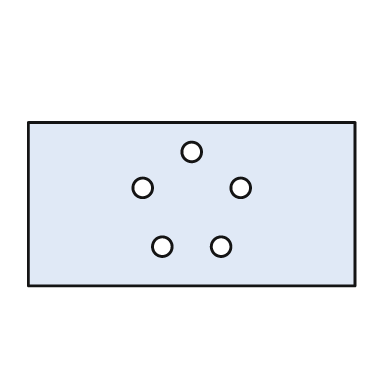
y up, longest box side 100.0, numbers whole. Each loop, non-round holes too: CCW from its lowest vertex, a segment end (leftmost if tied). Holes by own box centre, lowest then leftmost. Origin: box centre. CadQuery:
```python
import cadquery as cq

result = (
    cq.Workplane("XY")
    .moveTo(-50.0, -25.0)
    .lineTo(50.0, -25.0)
    .lineTo(50.0, 25.0)
    .lineTo(-50.0, 25.0)
    .close()
    .moveTo(-9.0, -13.0)
    .circle(3.0)
    .moveTo(9.0, -13.0)
    .circle(3.0)
    .moveTo(-15.0, 5.0)
    .circle(3.0)
    .moveTo(15.0, 5.0)
    .circle(3.0)
    .moveTo(0.0, 16.0)
    .circle(3.0)
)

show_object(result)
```